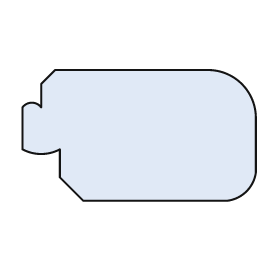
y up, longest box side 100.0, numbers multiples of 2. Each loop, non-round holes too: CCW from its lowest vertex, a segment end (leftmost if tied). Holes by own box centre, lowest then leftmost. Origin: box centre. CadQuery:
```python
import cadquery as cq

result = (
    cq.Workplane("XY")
    .moveTo(-24.0, -28.0)
    .lineTo(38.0, -28.0)
    .threePointArc((46.0, -24.0), (50.0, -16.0))
    .lineTo(50.0, 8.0)
    .threePointArc((44.0, 22.0), (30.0, 28.0))
    .lineTo(-36.0, 28.0)
    .lineTo(-42.0, 22.0)
    .lineTo(-42.0, 12.0)
    .threePointArc((-46.0, 14.0), (-50.0, 12.0))
    .lineTo(-50.0, -6.0)
    .threePointArc((-42.0, -8.0), (-34.0, -6.0))
    .lineTo(-34.0, -18.0)
    .close()
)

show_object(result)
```